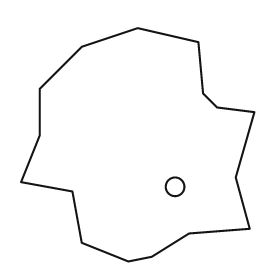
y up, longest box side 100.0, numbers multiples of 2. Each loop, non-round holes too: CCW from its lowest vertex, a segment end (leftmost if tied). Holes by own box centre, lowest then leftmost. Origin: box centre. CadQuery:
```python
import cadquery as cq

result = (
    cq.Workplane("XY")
    .moveTo(-4.0, -50.0)
    .lineTo(6.0, -48.0)
    .lineTo(22.0, -38.0)
    .lineTo(48.0, -36.0)
    .lineTo(42.0, -14.0)
    .lineTo(50.0, 14.0)
    .lineTo(34.0, 16.0)
    .lineTo(28.0, 22.0)
    .lineTo(26.0, 44.0)
    .lineTo(0.0, 50.0)
    .lineTo(-24.0, 42.0)
    .lineTo(-42.0, 24.0)
    .lineTo(-42.0, 4.0)
    .lineTo(-50.0, -16.0)
    .lineTo(-28.0, -20.0)
    .lineTo(-24.0, -42.0)
    .close()
    .moveTo(16.0, -18.0)
    .circle(4.0)
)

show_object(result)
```